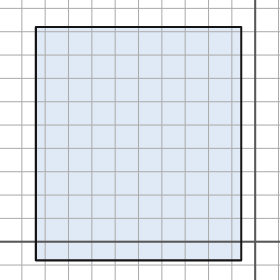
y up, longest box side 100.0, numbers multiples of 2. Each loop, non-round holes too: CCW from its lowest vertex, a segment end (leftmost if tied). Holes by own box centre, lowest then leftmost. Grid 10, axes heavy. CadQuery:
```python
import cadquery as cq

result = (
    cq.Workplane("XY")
    .moveTo(-94.0, -8.0)
    .lineTo(-6.0, -8.0)
    .lineTo(-6.0, 92.0)
    .lineTo(-94.0, 92.0)
    .close()
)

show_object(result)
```